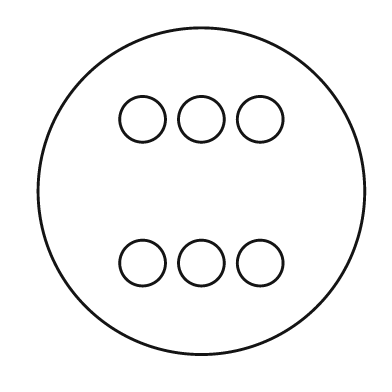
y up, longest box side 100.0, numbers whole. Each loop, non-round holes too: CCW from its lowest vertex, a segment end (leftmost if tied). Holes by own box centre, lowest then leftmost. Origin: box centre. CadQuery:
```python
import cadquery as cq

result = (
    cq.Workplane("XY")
    .moveTo(0.0, 0.0)
    .circle(50.0)
    .moveTo(-18.0, -22.0)
    .circle(7.0)
    .moveTo(0.0, -22.0)
    .circle(7.0)
    .moveTo(18.0, -22.0)
    .circle(7.0)
    .moveTo(-18.0, 22.0)
    .circle(7.0)
    .moveTo(0.0, 22.0)
    .circle(7.0)
    .moveTo(18.0, 22.0)
    .circle(7.0)
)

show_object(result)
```